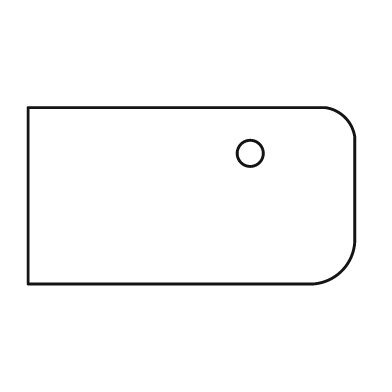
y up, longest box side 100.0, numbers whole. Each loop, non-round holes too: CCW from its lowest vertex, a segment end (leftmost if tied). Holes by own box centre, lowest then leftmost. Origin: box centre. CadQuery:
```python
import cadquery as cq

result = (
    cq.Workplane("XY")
    .moveTo(-50.0, -27.0)
    .lineTo(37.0, -27.0)
    .threePointArc((46.0, -23.0), (50.0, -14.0))
    .lineTo(50.0, 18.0)
    .threePointArc((47.0, 24.0), (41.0, 27.0))
    .lineTo(-50.0, 27.0)
    .close()
    .moveTo(18.0, 13.0)
    .circle(4.0)
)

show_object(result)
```